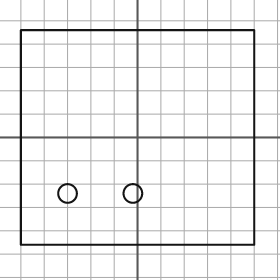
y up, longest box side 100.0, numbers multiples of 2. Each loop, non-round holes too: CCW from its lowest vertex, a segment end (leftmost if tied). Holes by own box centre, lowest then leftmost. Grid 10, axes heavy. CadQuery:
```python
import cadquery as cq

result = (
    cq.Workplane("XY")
    .moveTo(-50.0, -46.0)
    .lineTo(50.0, -46.0)
    .lineTo(50.0, 46.0)
    .lineTo(-50.0, 46.0)
    .close()
    .moveTo(-30.0, -24.0)
    .circle(4.0)
    .moveTo(-2.0, -24.0)
    .circle(4.0)
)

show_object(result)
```